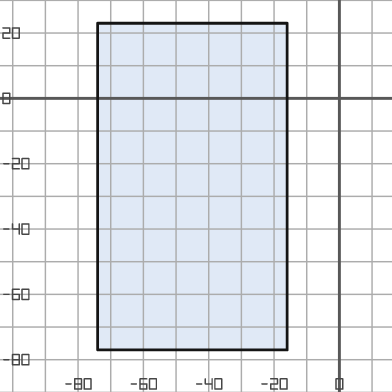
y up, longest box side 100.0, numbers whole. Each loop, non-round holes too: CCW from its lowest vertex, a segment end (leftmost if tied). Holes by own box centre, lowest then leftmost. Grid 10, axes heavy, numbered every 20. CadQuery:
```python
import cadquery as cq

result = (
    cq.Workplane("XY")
    .moveTo(-74.0, -77.0)
    .lineTo(-16.0, -77.0)
    .lineTo(-16.0, 23.0)
    .lineTo(-74.0, 23.0)
    .close()
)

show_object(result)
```